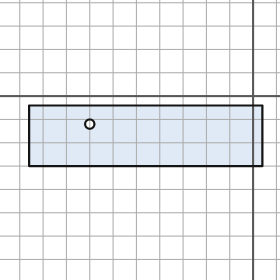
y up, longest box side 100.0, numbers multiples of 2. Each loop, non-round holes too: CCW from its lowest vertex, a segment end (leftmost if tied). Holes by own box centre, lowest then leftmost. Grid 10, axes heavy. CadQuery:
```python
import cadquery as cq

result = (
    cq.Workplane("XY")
    .moveTo(-96.0, -30.0)
    .lineTo(4.0, -30.0)
    .lineTo(4.0, -4.0)
    .lineTo(-96.0, -4.0)
    .close()
    .moveTo(-70.0, -12.0)
    .circle(2.0)
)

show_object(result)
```